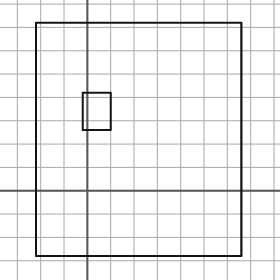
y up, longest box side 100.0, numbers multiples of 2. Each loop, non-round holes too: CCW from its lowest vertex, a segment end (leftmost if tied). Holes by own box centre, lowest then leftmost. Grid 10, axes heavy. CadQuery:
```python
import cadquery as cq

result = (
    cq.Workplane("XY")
    .moveTo(-22.0, -28.0)
    .lineTo(66.0, -28.0)
    .lineTo(66.0, 72.0)
    .lineTo(-22.0, 72.0)
    .close()
    .moveTo(-2.0, 26.0)
    .lineTo(10.0, 26.0)
    .lineTo(10.0, 42.0)
    .lineTo(-2.0, 42.0)
    .close()
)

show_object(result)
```